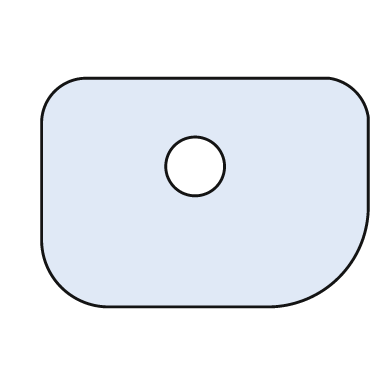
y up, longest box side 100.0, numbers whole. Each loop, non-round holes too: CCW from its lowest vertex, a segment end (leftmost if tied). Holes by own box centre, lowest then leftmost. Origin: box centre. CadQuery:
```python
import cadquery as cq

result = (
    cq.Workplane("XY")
    .moveTo(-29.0, -35.0)
    .lineTo(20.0, -35.0)
    .threePointArc((41.0, -26.0), (50.0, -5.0))
    .lineTo(50.0, 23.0)
    .threePointArc((46.0, 31.0), (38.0, 35.0))
    .lineTo(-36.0, 35.0)
    .threePointArc((-46.0, 31.0), (-50.0, 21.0))
    .lineTo(-50.0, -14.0)
    .threePointArc((-44.0, -29.0), (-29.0, -35.0))
    .close()
    .moveTo(-3.0, 8.0)
    .circle(9.0)
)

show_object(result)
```